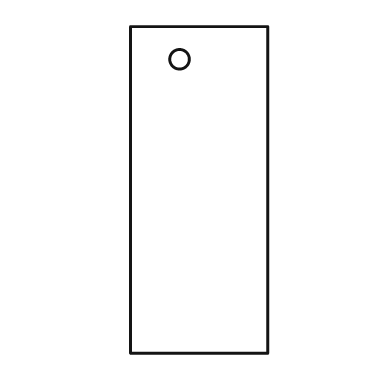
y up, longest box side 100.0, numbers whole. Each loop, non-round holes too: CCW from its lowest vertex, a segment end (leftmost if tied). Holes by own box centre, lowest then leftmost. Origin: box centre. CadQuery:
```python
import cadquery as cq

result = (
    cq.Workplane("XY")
    .moveTo(-21.0, -50.0)
    .lineTo(21.0, -50.0)
    .lineTo(21.0, 50.0)
    .lineTo(-21.0, 50.0)
    .close()
    .moveTo(-6.0, 40.0)
    .circle(3.0)
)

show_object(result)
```